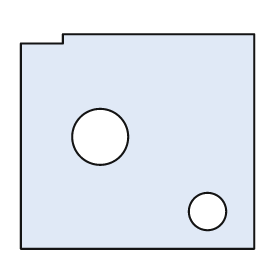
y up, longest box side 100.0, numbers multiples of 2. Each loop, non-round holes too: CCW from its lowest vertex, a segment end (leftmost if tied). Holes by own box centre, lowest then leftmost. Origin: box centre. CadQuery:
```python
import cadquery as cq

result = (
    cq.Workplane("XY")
    .moveTo(-50.0, -46.0)
    .lineTo(50.0, -46.0)
    .lineTo(50.0, 46.0)
    .lineTo(-32.0, 46.0)
    .lineTo(-32.0, 42.0)
    .lineTo(-50.0, 42.0)
    .close()
    .moveTo(30.0, -30.0)
    .circle(8.0)
    .moveTo(-16.0, 2.0)
    .circle(12.0)
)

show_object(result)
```